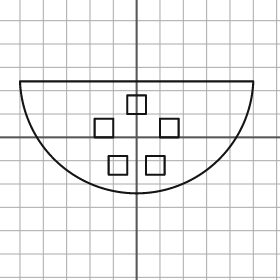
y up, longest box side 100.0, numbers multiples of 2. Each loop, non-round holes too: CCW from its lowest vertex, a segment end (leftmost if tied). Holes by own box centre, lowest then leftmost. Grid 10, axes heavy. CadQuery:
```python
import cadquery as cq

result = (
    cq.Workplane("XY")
    .moveTo(-50.0, 24.0)
    .threePointArc((0.0, -24.0), (50.0, 24.0))
    .close()
    .moveTo(-12.0, -16.0)
    .lineTo(-4.0, -16.0)
    .lineTo(-4.0, -8.0)
    .lineTo(-12.0, -8.0)
    .close()
    .moveTo(4.0, -16.0)
    .lineTo(12.0, -16.0)
    .lineTo(12.0, -8.0)
    .lineTo(4.0, -8.0)
    .close()
    .moveTo(-18.0, 0.0)
    .lineTo(-10.0, 0.0)
    .lineTo(-10.0, 8.0)
    .lineTo(-18.0, 8.0)
    .close()
    .moveTo(10.0, 0.0)
    .lineTo(18.0, 0.0)
    .lineTo(18.0, 8.0)
    .lineTo(10.0, 8.0)
    .close()
    .moveTo(-4.0, 10.0)
    .lineTo(4.0, 10.0)
    .lineTo(4.0, 18.0)
    .lineTo(-4.0, 18.0)
    .close()
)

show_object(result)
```